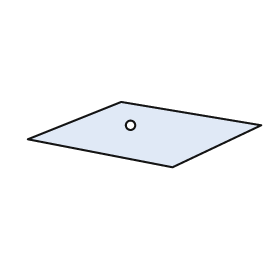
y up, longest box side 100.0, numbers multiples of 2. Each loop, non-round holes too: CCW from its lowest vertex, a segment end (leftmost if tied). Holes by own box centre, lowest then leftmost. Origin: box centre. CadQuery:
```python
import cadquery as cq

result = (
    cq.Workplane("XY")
    .moveTo(12.0, -14.0)
    .lineTo(50.0, 4.0)
    .lineTo(-10.0, 14.0)
    .lineTo(-50.0, -2.0)
    .close()
    .moveTo(-6.0, 4.0)
    .circle(2.0)
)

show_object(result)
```